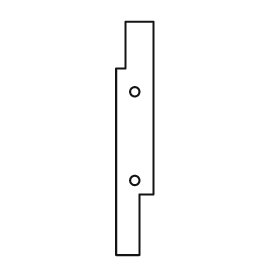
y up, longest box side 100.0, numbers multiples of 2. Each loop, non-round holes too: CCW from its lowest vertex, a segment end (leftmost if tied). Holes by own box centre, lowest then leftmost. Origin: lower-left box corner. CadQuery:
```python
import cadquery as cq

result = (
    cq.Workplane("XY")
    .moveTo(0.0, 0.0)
    .lineTo(10.0, 0.0)
    .lineTo(10.0, 26.0)
    .lineTo(16.0, 26.0)
    .lineTo(16.0, 100.0)
    .lineTo(4.0, 100.0)
    .lineTo(4.0, 80.0)
    .lineTo(0.0, 80.0)
    .close()
    .moveTo(8.0, 32.0)
    .circle(2.0)
    .moveTo(8.0, 70.0)
    .circle(2.0)
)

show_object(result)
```